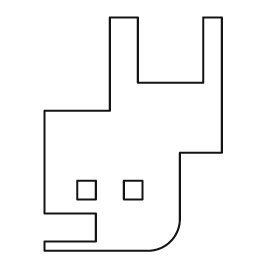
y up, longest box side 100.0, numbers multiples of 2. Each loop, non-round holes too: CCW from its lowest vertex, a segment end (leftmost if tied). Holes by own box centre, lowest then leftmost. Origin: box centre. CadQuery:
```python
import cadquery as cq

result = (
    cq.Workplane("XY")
    .moveTo(-38.0, -50.0)
    .lineTo(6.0, -50.0)
    .threePointArc((16.0, -46.0), (20.0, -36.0))
    .lineTo(20.0, -8.0)
    .lineTo(38.0, -8.0)
    .lineTo(38.0, 50.0)
    .lineTo(30.0, 50.0)
    .lineTo(30.0, 22.0)
    .lineTo(2.0, 22.0)
    .lineTo(2.0, 50.0)
    .lineTo(-10.0, 50.0)
    .lineTo(-10.0, 10.0)
    .lineTo(-38.0, 10.0)
    .lineTo(-38.0, -34.0)
    .lineTo(-16.0, -34.0)
    .lineTo(-16.0, -46.0)
    .lineTo(-38.0, -46.0)
    .close()
    .moveTo(-24.0, -28.0)
    .lineTo(-16.0, -28.0)
    .lineTo(-16.0, -20.0)
    .lineTo(-24.0, -20.0)
    .close()
    .moveTo(-4.0, -28.0)
    .lineTo(4.0, -28.0)
    .lineTo(4.0, -20.0)
    .lineTo(-4.0, -20.0)
    .close()
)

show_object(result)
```